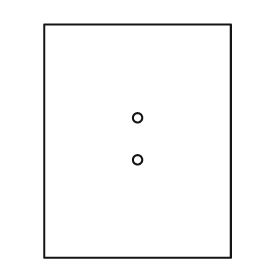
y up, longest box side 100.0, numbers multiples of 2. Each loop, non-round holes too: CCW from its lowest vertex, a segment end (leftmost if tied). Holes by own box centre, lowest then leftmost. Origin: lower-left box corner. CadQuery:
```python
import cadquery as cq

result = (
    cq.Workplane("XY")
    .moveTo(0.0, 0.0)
    .lineTo(80.0, 0.0)
    .lineTo(80.0, 100.0)
    .lineTo(0.0, 100.0)
    .close()
    .moveTo(40.0, 42.0)
    .circle(2.0)
    .moveTo(40.0, 60.0)
    .circle(2.0)
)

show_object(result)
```